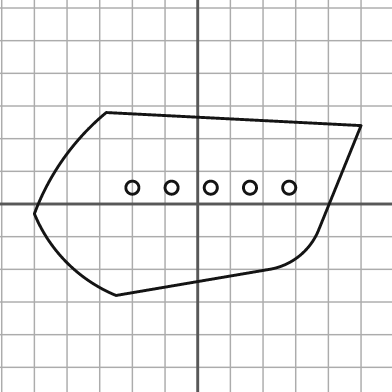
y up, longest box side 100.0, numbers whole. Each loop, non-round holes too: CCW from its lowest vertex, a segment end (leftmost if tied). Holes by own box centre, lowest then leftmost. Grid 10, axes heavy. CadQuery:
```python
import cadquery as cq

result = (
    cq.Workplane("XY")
    .moveTo(-25.0, -28.0)
    .lineTo(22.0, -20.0)
    .threePointArc((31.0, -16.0), (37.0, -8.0))
    .lineTo(50.0, 24.0)
    .lineTo(-28.0, 28.0)
    .threePointArc((-41.0, 14.0), (-50.0, -3.0))
    .threePointArc((-40.0, -18.0), (-25.0, -28.0))
    .close()
    .moveTo(-20.0, 5.0)
    .circle(2.0)
    .moveTo(-8.0, 5.0)
    .circle(2.0)
    .moveTo(4.0, 5.0)
    .circle(2.0)
    .moveTo(16.0, 5.0)
    .circle(2.0)
    .moveTo(28.0, 5.0)
    .circle(2.0)
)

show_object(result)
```